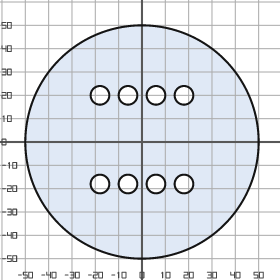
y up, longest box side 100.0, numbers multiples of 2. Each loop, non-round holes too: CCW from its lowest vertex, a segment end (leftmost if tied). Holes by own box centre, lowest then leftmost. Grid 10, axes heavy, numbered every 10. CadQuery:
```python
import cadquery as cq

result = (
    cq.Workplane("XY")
    .moveTo(0.0, 0.0)
    .circle(50.0)
    .moveTo(-18.0, -18.0)
    .circle(4.0)
    .moveTo(-6.0, -18.0)
    .circle(4.0)
    .moveTo(6.0, -18.0)
    .circle(4.0)
    .moveTo(18.0, -18.0)
    .circle(4.0)
    .moveTo(-18.0, 20.0)
    .circle(4.0)
    .moveTo(-6.0, 20.0)
    .circle(4.0)
    .moveTo(6.0, 20.0)
    .circle(4.0)
    .moveTo(18.0, 20.0)
    .circle(4.0)
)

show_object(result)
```